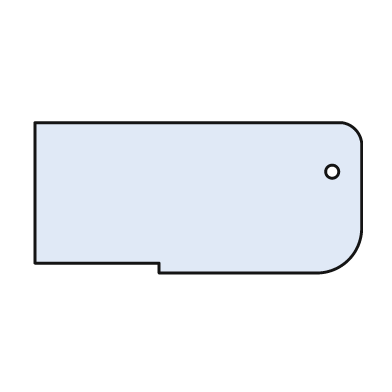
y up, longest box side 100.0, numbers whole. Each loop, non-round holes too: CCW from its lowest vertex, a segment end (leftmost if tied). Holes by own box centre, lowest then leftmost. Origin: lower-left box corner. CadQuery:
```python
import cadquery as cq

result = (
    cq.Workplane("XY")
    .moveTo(38.0, 0.0)
    .lineTo(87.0, 0.0)
    .threePointArc((96.0, 4.0), (100.0, 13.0))
    .lineTo(100.0, 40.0)
    .threePointArc((98.0, 44.0), (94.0, 46.0))
    .lineTo(0.0, 46.0)
    .lineTo(0.0, 3.0)
    .lineTo(38.0, 3.0)
    .close()
    .moveTo(91.0, 31.0)
    .circle(2.0)
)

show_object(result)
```